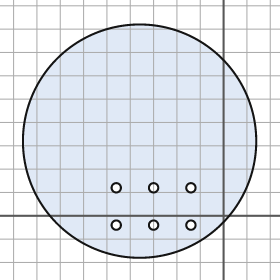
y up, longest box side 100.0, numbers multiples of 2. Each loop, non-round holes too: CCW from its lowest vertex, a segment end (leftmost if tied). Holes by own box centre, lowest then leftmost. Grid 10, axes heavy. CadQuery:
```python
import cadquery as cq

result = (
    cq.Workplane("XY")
    .moveTo(-36.0, 32.0)
    .circle(50.0)
    .moveTo(-46.0, -4.0)
    .circle(2.0)
    .moveTo(-30.0, -4.0)
    .circle(2.0)
    .moveTo(-14.0, -4.0)
    .circle(2.0)
    .moveTo(-46.0, 12.0)
    .circle(2.0)
    .moveTo(-30.0, 12.0)
    .circle(2.0)
    .moveTo(-14.0, 12.0)
    .circle(2.0)
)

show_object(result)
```